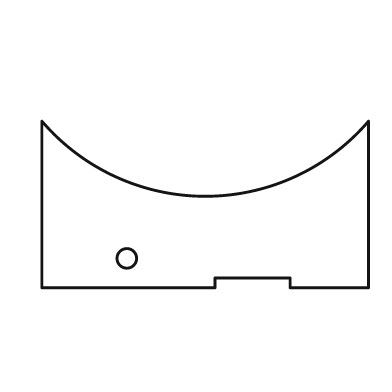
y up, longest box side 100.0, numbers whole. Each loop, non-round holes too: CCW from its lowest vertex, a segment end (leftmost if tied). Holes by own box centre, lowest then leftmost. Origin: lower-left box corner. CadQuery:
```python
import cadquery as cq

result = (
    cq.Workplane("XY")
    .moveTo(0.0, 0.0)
    .lineTo(53.0, 0.0)
    .lineTo(53.0, 3.0)
    .lineTo(76.0, 3.0)
    .lineTo(76.0, 0.0)
    .lineTo(100.0, 0.0)
    .lineTo(100.0, 51.0)
    .threePointArc((50.0, 28.0), (0.0, 51.0))
    .close()
    .moveTo(26.0, 9.0)
    .circle(3.0)
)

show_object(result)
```